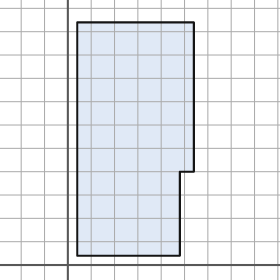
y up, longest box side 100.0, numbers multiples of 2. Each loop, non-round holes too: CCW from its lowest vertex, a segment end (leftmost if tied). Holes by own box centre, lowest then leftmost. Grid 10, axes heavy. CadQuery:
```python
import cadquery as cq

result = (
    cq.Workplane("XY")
    .moveTo(4.0, 4.0)
    .lineTo(48.0, 4.0)
    .lineTo(48.0, 40.0)
    .lineTo(54.0, 40.0)
    .lineTo(54.0, 104.0)
    .lineTo(4.0, 104.0)
    .close()
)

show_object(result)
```